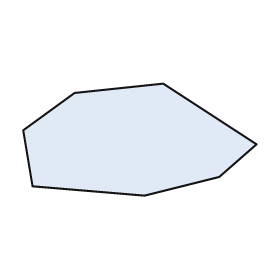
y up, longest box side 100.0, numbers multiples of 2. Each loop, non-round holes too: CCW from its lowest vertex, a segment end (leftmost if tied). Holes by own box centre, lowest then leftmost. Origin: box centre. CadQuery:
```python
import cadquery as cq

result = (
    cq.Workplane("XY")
    .moveTo(2.0, -24.0)
    .lineTo(34.0, -16.0)
    .lineTo(50.0, -2.0)
    .lineTo(10.0, 24.0)
    .lineTo(-28.0, 20.0)
    .lineTo(-50.0, 4.0)
    .lineTo(-46.0, -20.0)
    .close()
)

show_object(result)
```